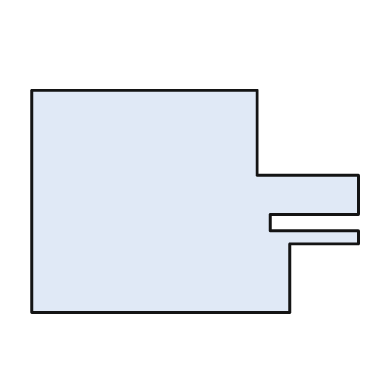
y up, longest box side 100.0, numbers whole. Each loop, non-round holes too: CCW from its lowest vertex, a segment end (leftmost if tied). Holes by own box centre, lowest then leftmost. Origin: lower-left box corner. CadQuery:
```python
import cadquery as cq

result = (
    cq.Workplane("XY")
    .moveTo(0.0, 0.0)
    .lineTo(79.0, 0.0)
    .lineTo(79.0, 21.0)
    .lineTo(100.0, 21.0)
    .lineTo(100.0, 25.0)
    .lineTo(73.0, 25.0)
    .lineTo(73.0, 30.0)
    .lineTo(100.0, 30.0)
    .lineTo(100.0, 42.0)
    .lineTo(69.0, 42.0)
    .lineTo(69.0, 68.0)
    .lineTo(0.0, 68.0)
    .close()
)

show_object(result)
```